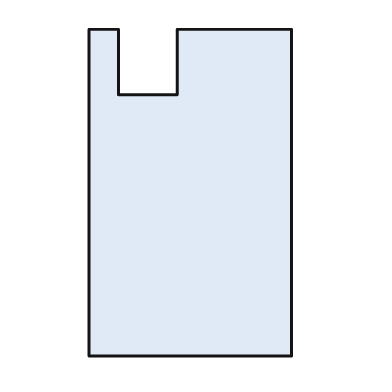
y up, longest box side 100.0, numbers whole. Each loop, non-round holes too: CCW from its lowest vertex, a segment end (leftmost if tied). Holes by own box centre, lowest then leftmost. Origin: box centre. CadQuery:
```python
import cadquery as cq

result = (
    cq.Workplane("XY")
    .moveTo(-31.0, -50.0)
    .lineTo(31.0, -50.0)
    .lineTo(31.0, 50.0)
    .lineTo(-4.0, 50.0)
    .lineTo(-4.0, 30.0)
    .lineTo(-22.0, 30.0)
    .lineTo(-22.0, 50.0)
    .lineTo(-31.0, 50.0)
    .close()
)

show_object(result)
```